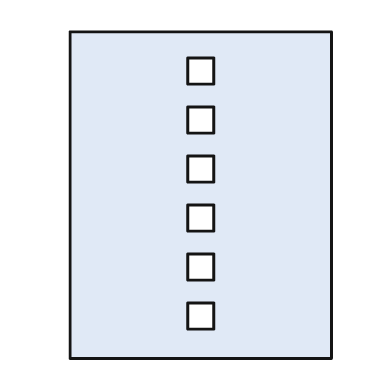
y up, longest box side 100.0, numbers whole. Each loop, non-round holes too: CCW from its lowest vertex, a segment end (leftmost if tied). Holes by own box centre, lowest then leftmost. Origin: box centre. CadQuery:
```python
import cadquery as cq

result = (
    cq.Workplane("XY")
    .moveTo(-40.0, -50.0)
    .lineTo(40.0, -50.0)
    .lineTo(40.0, 50.0)
    .lineTo(-40.0, 50.0)
    .close()
    .moveTo(-4.0, -41.0)
    .lineTo(4.0, -41.0)
    .lineTo(4.0, -33.0)
    .lineTo(-4.0, -33.0)
    .close()
    .moveTo(-4.0, -26.0)
    .lineTo(4.0, -26.0)
    .lineTo(4.0, -18.0)
    .lineTo(-4.0, -18.0)
    .close()
    .moveTo(-4.0, -11.0)
    .lineTo(4.0, -11.0)
    .lineTo(4.0, -3.0)
    .lineTo(-4.0, -3.0)
    .close()
    .moveTo(-4.0, 4.0)
    .lineTo(4.0, 4.0)
    .lineTo(4.0, 12.0)
    .lineTo(-4.0, 12.0)
    .close()
    .moveTo(-4.0, 19.0)
    .lineTo(4.0, 19.0)
    .lineTo(4.0, 27.0)
    .lineTo(-4.0, 27.0)
    .close()
    .moveTo(-4.0, 34.0)
    .lineTo(4.0, 34.0)
    .lineTo(4.0, 42.0)
    .lineTo(-4.0, 42.0)
    .close()
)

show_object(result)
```